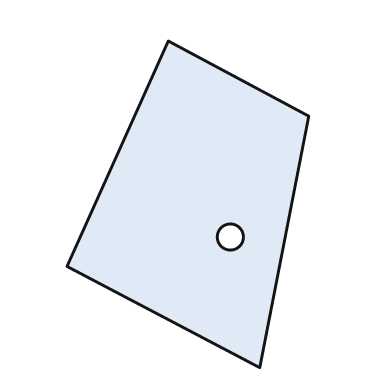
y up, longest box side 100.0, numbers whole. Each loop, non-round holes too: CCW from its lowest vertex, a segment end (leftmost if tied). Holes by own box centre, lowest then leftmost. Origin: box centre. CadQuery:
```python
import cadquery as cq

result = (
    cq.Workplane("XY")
    .moveTo(22.0, -50.0)
    .lineTo(37.0, 27.0)
    .lineTo(-6.0, 50.0)
    .lineTo(-37.0, -19.0)
    .close()
    .moveTo(13.0, -10.0)
    .circle(4.0)
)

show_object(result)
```